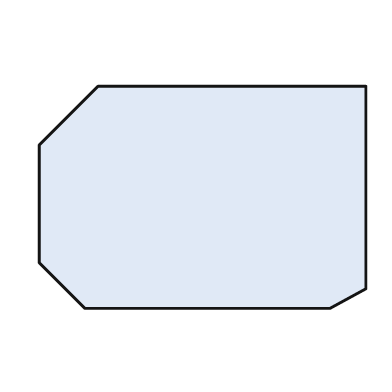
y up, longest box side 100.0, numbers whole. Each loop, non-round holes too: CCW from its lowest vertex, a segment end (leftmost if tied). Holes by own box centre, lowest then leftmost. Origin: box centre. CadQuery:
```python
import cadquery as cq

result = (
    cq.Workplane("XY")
    .moveTo(-36.0, -34.0)
    .lineTo(39.0, -34.0)
    .lineTo(50.0, -28.0)
    .lineTo(50.0, 34.0)
    .lineTo(-32.0, 34.0)
    .lineTo(-50.0, 16.0)
    .lineTo(-50.0, -20.0)
    .close()
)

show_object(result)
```